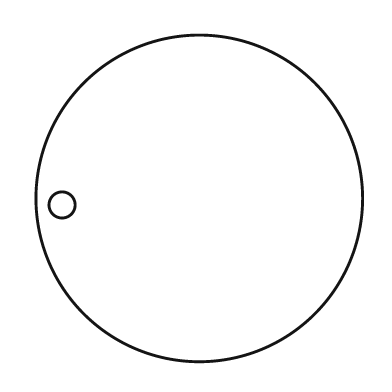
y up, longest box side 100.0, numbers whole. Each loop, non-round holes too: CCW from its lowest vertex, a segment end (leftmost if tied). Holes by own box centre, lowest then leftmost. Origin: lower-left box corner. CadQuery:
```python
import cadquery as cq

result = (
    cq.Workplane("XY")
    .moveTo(50.0, 50.0)
    .circle(50.0)
    .moveTo(8.0, 48.0)
    .circle(4.0)
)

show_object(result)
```